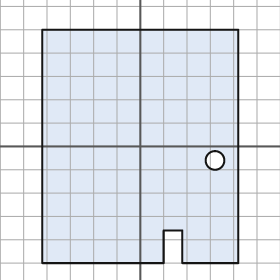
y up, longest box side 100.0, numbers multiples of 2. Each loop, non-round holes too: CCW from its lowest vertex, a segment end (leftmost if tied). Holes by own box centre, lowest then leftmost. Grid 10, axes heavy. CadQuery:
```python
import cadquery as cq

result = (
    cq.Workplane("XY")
    .moveTo(-42.0, -50.0)
    .lineTo(10.0, -50.0)
    .lineTo(10.0, -36.0)
    .lineTo(18.0, -36.0)
    .lineTo(18.0, -50.0)
    .lineTo(42.0, -50.0)
    .lineTo(42.0, 50.0)
    .lineTo(-42.0, 50.0)
    .close()
    .moveTo(32.0, -6.0)
    .circle(4.0)
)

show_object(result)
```